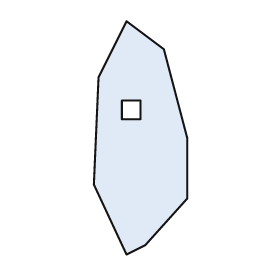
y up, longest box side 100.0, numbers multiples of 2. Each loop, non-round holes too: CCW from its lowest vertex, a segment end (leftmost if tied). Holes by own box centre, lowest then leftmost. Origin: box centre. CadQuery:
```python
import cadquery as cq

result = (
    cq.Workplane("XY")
    .moveTo(-6.0, -50.0)
    .lineTo(2.0, -46.0)
    .lineTo(20.0, -26.0)
    .lineTo(20.0, 0.0)
    .lineTo(10.0, 38.0)
    .lineTo(-6.0, 50.0)
    .lineTo(-18.0, 26.0)
    .lineTo(-20.0, -20.0)
    .close()
    .moveTo(-8.0, 8.0)
    .lineTo(0.0, 8.0)
    .lineTo(0.0, 16.0)
    .lineTo(-8.0, 16.0)
    .close()
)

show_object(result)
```